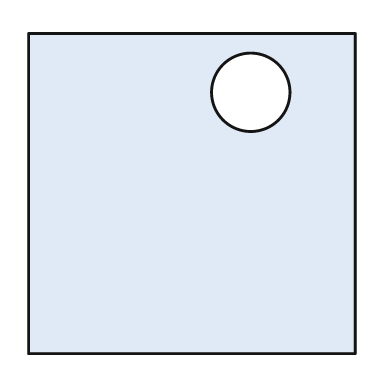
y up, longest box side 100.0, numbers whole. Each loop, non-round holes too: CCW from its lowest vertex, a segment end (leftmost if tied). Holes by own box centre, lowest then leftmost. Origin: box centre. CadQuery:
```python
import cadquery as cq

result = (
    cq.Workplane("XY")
    .moveTo(-50.0, -49.0)
    .lineTo(50.0, -49.0)
    .lineTo(50.0, 49.0)
    .lineTo(-50.0, 49.0)
    .close()
    .moveTo(18.0, 31.0)
    .circle(12.0)
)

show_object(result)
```